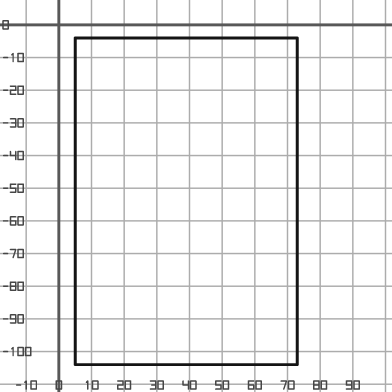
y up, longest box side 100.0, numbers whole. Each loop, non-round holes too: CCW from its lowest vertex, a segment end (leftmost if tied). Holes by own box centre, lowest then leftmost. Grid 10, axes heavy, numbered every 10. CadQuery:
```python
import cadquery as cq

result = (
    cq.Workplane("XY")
    .moveTo(5.0, -104.0)
    .lineTo(73.0, -104.0)
    .lineTo(73.0, -4.0)
    .lineTo(5.0, -4.0)
    .close()
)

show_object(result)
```